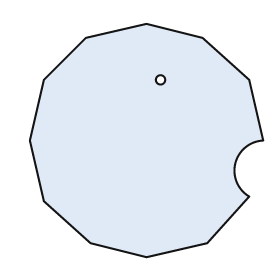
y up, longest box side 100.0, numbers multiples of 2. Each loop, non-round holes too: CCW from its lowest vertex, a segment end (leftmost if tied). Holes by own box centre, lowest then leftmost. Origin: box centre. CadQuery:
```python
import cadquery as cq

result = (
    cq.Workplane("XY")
    .moveTo(0.0, -50.0)
    .lineTo(26.0, -44.0)
    .lineTo(44.0, -24.0)
    .threePointArc((38.0, -10.0), (50.0, 0.0))
    .lineTo(44.0, 26.0)
    .lineTo(24.0, 44.0)
    .lineTo(0.0, 50.0)
    .lineTo(-26.0, 44.0)
    .lineTo(-44.0, 26.0)
    .lineTo(-50.0, 0.0)
    .lineTo(-44.0, -26.0)
    .lineTo(-24.0, -44.0)
    .close()
    .moveTo(6.0, 26.0)
    .circle(2.0)
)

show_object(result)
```